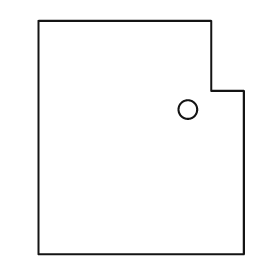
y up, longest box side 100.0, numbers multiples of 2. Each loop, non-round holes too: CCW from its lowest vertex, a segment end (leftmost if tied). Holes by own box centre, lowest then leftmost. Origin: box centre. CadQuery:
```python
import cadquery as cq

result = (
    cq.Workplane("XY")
    .moveTo(-44.0, -50.0)
    .lineTo(44.0, -50.0)
    .lineTo(44.0, 20.0)
    .lineTo(30.0, 20.0)
    .lineTo(30.0, 50.0)
    .lineTo(-44.0, 50.0)
    .close()
    .moveTo(20.0, 12.0)
    .circle(4.0)
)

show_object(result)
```